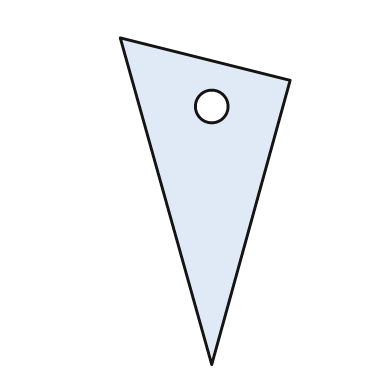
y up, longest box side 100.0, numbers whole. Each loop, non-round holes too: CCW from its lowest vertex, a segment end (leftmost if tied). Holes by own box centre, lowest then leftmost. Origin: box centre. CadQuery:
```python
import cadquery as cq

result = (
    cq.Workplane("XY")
    .moveTo(2.0, -50.0)
    .lineTo(26.0, 37.0)
    .lineTo(-26.0, 50.0)
    .close()
    .moveTo(2.0, 29.0)
    .circle(5.0)
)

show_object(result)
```